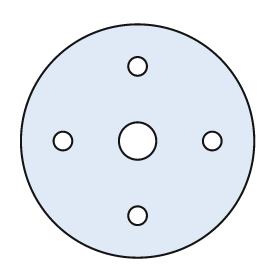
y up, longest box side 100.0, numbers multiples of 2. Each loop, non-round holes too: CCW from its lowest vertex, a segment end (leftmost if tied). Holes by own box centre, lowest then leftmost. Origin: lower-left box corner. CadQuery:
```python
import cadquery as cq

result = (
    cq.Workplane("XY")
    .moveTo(50.0, 50.0)
    .circle(50.0)
    .moveTo(50.0, 18.0)
    .circle(4.0)
    .moveTo(18.0, 50.0)
    .circle(4.0)
    .moveTo(50.0, 50.0)
    .circle(8.0)
    .moveTo(82.0, 50.0)
    .circle(4.0)
    .moveTo(50.0, 82.0)
    .circle(4.0)
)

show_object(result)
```